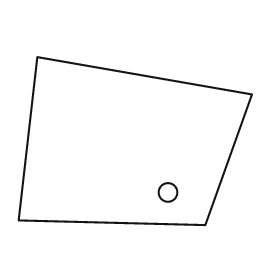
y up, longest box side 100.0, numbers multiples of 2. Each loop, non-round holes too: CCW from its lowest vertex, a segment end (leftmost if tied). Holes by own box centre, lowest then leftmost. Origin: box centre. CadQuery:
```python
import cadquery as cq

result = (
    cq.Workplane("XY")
    .moveTo(30.0, -36.0)
    .lineTo(50.0, 20.0)
    .lineTo(-42.0, 36.0)
    .lineTo(-50.0, -34.0)
    .close()
    .moveTo(14.0, -22.0)
    .circle(4.0)
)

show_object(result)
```